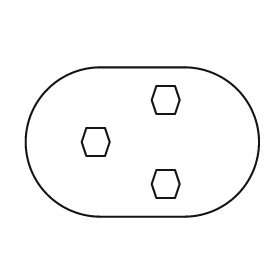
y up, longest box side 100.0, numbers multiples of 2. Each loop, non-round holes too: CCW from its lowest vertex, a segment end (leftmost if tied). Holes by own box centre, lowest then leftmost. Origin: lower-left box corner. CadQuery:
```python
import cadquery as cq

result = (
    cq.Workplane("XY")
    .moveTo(32.0, 0.0)
    .lineTo(68.0, 0.0)
    .threePointArc((100.0, 32.0), (68.0, 64.0))
    .lineTo(32.0, 64.0)
    .threePointArc((0.0, 32.0), (32.0, 0.0))
    .close()
    .moveTo(56.0, 8.0)
    .lineTo(64.0, 8.0)
    .lineTo(66.0, 14.0)
    .lineTo(64.0, 20.0)
    .lineTo(56.0, 20.0)
    .lineTo(54.0, 14.0)
    .close()
    .moveTo(26.0, 26.0)
    .lineTo(34.0, 26.0)
    .lineTo(36.0, 32.0)
    .lineTo(34.0, 38.0)
    .lineTo(26.0, 38.0)
    .lineTo(24.0, 32.0)
    .close()
    .moveTo(56.0, 44.0)
    .lineTo(64.0, 44.0)
    .lineTo(66.0, 50.0)
    .lineTo(64.0, 56.0)
    .lineTo(56.0, 56.0)
    .lineTo(54.0, 50.0)
    .close()
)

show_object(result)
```